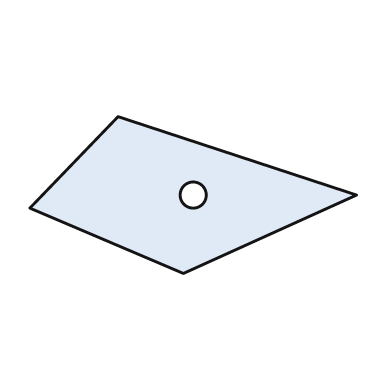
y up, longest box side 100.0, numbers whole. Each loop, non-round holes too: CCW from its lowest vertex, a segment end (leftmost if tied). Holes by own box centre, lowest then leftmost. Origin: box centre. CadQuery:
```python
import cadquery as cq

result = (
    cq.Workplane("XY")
    .moveTo(-3.0, -24.0)
    .lineTo(50.0, 0.0)
    .lineTo(-23.0, 24.0)
    .lineTo(-50.0, -4.0)
    .close()
    .moveTo(0.0, 0.0)
    .circle(4.0)
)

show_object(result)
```